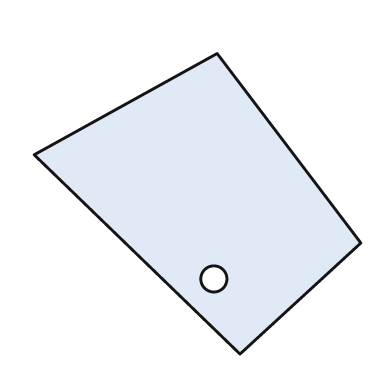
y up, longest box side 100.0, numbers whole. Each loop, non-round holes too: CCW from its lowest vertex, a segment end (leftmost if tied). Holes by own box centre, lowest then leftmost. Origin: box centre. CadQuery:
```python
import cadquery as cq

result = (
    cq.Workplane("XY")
    .moveTo(13.0, -46.0)
    .lineTo(50.0, -12.0)
    .lineTo(6.0, 46.0)
    .lineTo(-50.0, 15.0)
    .close()
    .moveTo(5.0, -23.0)
    .circle(4.0)
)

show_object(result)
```